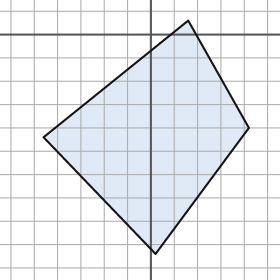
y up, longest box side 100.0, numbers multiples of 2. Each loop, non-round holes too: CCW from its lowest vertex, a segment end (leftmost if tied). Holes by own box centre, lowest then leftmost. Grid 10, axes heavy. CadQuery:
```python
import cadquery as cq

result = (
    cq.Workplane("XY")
    .moveTo(2.0, -94.0)
    .lineTo(42.0, -40.0)
    .lineTo(16.0, 6.0)
    .lineTo(-46.0, -44.0)
    .close()
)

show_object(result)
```